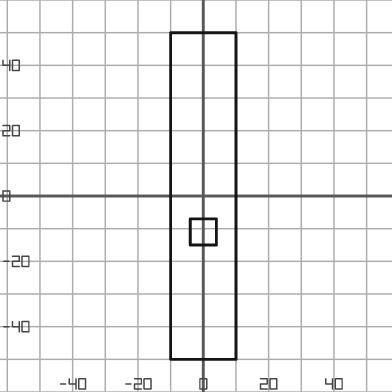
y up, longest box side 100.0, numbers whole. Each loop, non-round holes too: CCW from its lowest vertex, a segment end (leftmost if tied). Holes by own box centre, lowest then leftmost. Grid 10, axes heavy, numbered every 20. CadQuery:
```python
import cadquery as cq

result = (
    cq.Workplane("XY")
    .moveTo(-10.0, -50.0)
    .lineTo(10.0, -50.0)
    .lineTo(10.0, 50.0)
    .lineTo(-10.0, 50.0)
    .close()
    .moveTo(-4.0, -15.0)
    .lineTo(4.0, -15.0)
    .lineTo(4.0, -7.0)
    .lineTo(-4.0, -7.0)
    .close()
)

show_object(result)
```